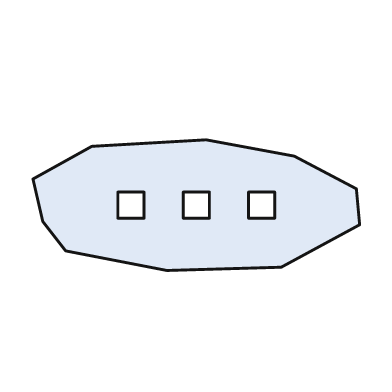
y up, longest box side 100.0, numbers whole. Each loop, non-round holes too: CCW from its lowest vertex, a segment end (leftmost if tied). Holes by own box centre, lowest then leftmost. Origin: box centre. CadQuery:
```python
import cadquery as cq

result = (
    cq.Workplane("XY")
    .moveTo(-9.0, -20.0)
    .lineTo(26.0, -19.0)
    .lineTo(50.0, -6.0)
    .lineTo(49.0, 5.0)
    .lineTo(30.0, 15.0)
    .lineTo(3.0, 20.0)
    .lineTo(-32.0, 18.0)
    .lineTo(-50.0, 8.0)
    .lineTo(-47.0, -5.0)
    .lineTo(-40.0, -14.0)
    .close()
    .moveTo(-24.0, -4.0)
    .lineTo(-16.0, -4.0)
    .lineTo(-16.0, 4.0)
    .lineTo(-24.0, 4.0)
    .close()
    .moveTo(-4.0, -4.0)
    .lineTo(4.0, -4.0)
    .lineTo(4.0, 4.0)
    .lineTo(-4.0, 4.0)
    .close()
    .moveTo(16.0, -4.0)
    .lineTo(24.0, -4.0)
    .lineTo(24.0, 4.0)
    .lineTo(16.0, 4.0)
    .close()
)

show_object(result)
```